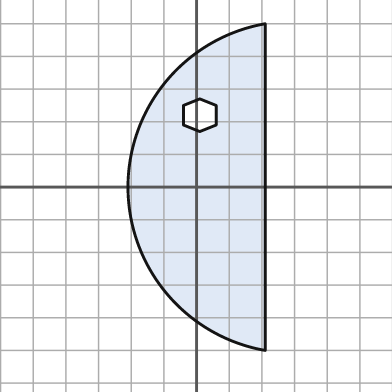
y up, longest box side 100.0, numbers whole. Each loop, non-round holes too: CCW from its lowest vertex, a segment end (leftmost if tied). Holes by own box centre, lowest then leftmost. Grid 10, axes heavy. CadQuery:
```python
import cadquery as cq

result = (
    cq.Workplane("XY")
    .moveTo(21.0, -50.0)
    .lineTo(21.0, 50.0)
    .threePointArc((-21.0, 0.0), (21.0, -50.0))
    .close()
    .moveTo(1.0, 17.0)
    .lineTo(6.0, 19.0)
    .lineTo(6.0, 25.0)
    .lineTo(1.0, 27.0)
    .lineTo(-4.0, 25.0)
    .lineTo(-4.0, 19.0)
    .close()
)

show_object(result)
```